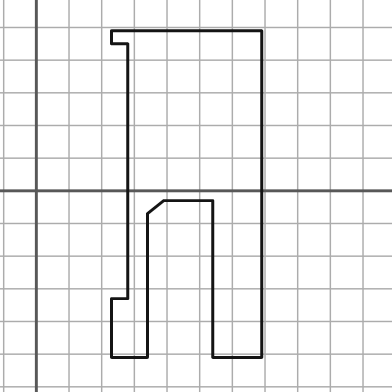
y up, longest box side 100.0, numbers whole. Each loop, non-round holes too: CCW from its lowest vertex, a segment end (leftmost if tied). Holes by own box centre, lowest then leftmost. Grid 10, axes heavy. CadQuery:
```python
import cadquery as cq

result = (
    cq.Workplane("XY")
    .moveTo(23.0, -51.0)
    .lineTo(34.0, -51.0)
    .lineTo(34.0, -7.0)
    .lineTo(39.0, -3.0)
    .lineTo(54.0, -3.0)
    .lineTo(54.0, -51.0)
    .lineTo(69.0, -51.0)
    .lineTo(69.0, 49.0)
    .lineTo(23.0, 49.0)
    .lineTo(23.0, 45.0)
    .lineTo(28.0, 45.0)
    .lineTo(28.0, -33.0)
    .lineTo(23.0, -33.0)
    .close()
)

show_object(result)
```